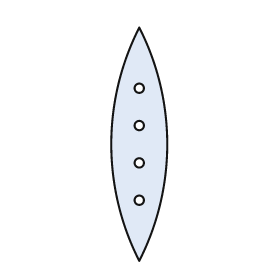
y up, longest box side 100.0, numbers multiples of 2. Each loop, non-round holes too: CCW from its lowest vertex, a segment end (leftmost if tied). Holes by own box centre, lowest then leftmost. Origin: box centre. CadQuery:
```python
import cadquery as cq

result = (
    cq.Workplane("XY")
    .moveTo(0.0, -50.0)
    .threePointArc((12.0, 0.0), (0.0, 50.0))
    .threePointArc((-12.0, 0.0), (0.0, -50.0))
    .close()
    .moveTo(0.0, -24.0)
    .circle(2.0)
    .moveTo(0.0, -8.0)
    .circle(2.0)
    .moveTo(0.0, 8.0)
    .circle(2.0)
    .moveTo(0.0, 24.0)
    .circle(2.0)
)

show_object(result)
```